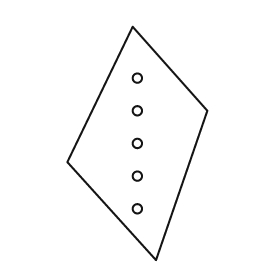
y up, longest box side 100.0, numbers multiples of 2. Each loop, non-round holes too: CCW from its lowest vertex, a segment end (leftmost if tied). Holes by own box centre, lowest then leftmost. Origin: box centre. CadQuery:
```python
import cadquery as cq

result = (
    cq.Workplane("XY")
    .moveTo(8.0, -50.0)
    .lineTo(30.0, 14.0)
    .lineTo(-2.0, 50.0)
    .lineTo(-30.0, -8.0)
    .close()
    .moveTo(0.0, -28.0)
    .circle(2.0)
    .moveTo(0.0, -14.0)
    .circle(2.0)
    .moveTo(0.0, 0.0)
    .circle(2.0)
    .moveTo(0.0, 14.0)
    .circle(2.0)
    .moveTo(0.0, 28.0)
    .circle(2.0)
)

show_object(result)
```